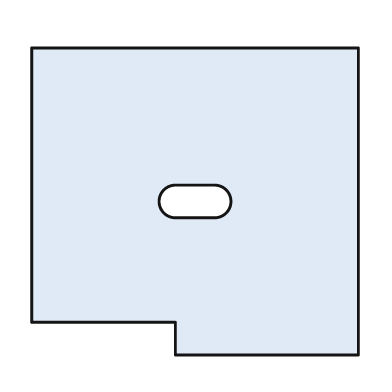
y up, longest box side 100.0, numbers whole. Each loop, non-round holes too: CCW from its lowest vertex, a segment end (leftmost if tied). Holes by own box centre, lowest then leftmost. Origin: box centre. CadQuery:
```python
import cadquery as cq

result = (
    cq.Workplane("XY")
    .moveTo(-6.0, -47.0)
    .lineTo(50.0, -47.0)
    .lineTo(50.0, 47.0)
    .lineTo(-50.0, 47.0)
    .lineTo(-50.0, -37.0)
    .lineTo(-6.0, -37.0)
    .close()
    .moveTo(-6.0, -5.0)
    .lineTo(6.0, -5.0)
    .threePointArc((11.0, 0.0), (6.0, 5.0))
    .lineTo(-6.0, 5.0)
    .threePointArc((-11.0, 0.0), (-6.0, -5.0))
    .close()
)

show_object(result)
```